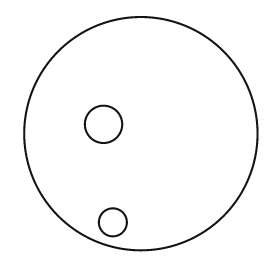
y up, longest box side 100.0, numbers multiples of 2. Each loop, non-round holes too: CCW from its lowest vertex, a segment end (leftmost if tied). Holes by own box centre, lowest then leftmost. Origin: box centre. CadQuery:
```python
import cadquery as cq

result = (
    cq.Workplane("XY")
    .moveTo(0.0, 0.0)
    .circle(50.0)
    .moveTo(-12.0, -38.0)
    .circle(6.0)
    .moveTo(-16.0, 4.0)
    .circle(8.0)
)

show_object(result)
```